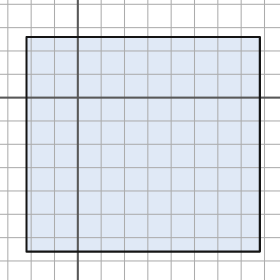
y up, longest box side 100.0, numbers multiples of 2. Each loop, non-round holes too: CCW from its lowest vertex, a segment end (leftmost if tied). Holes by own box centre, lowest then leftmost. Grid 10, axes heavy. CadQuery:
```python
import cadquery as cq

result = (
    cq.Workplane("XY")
    .moveTo(-22.0, -66.0)
    .lineTo(78.0, -66.0)
    .lineTo(78.0, 26.0)
    .lineTo(-22.0, 26.0)
    .close()
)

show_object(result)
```